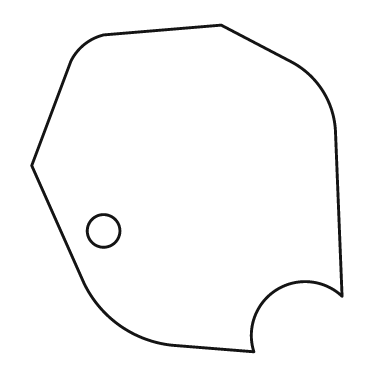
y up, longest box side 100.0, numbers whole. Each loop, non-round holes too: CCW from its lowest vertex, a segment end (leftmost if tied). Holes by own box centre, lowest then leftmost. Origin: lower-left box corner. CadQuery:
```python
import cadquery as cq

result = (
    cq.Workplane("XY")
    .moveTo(68.0, 0.0)
    .threePointArc((75.0, 19.0), (95.0, 17.0))
    .lineTo(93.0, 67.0)
    .threePointArc((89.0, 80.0), (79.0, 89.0))
    .lineTo(58.0, 100.0)
    .lineTo(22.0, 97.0)
    .threePointArc((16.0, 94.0), (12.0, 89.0))
    .lineTo(0.0, 57.0)
    .lineTo(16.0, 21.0)
    .threePointArc((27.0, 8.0), (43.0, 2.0))
    .close()
    .moveTo(22.0, 37.0)
    .circle(5.0)
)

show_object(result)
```